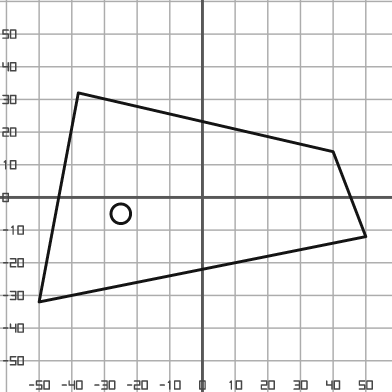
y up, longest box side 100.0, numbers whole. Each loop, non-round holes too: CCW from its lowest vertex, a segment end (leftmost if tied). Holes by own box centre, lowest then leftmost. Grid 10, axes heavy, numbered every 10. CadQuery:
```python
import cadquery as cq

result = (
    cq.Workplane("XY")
    .moveTo(-50.0, -32.0)
    .lineTo(50.0, -12.0)
    .lineTo(40.0, 14.0)
    .lineTo(-38.0, 32.0)
    .close()
    .moveTo(-25.0, -5.0)
    .circle(3.0)
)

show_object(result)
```